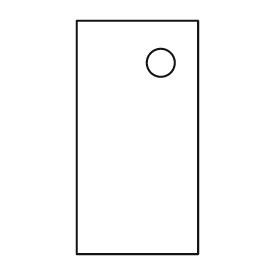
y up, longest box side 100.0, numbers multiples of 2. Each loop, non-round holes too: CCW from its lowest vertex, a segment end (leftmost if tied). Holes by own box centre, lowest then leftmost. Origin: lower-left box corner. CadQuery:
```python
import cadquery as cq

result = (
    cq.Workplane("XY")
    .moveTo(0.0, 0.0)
    .lineTo(52.0, 0.0)
    .lineTo(52.0, 100.0)
    .lineTo(0.0, 100.0)
    .close()
    .moveTo(36.0, 82.0)
    .circle(6.0)
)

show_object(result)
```